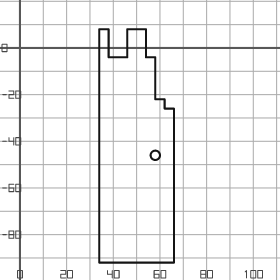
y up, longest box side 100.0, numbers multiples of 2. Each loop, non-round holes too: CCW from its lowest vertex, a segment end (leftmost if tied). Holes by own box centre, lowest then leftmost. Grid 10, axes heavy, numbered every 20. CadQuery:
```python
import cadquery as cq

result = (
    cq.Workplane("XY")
    .moveTo(34.0, -92.0)
    .lineTo(66.0, -92.0)
    .lineTo(66.0, -26.0)
    .lineTo(62.0, -26.0)
    .lineTo(62.0, -22.0)
    .lineTo(58.0, -22.0)
    .lineTo(58.0, -4.0)
    .lineTo(54.0, -4.0)
    .lineTo(54.0, 8.0)
    .lineTo(46.0, 8.0)
    .lineTo(46.0, -4.0)
    .lineTo(38.0, -4.0)
    .lineTo(38.0, 8.0)
    .lineTo(34.0, 8.0)
    .close()
    .moveTo(58.0, -46.0)
    .circle(2.0)
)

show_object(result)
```